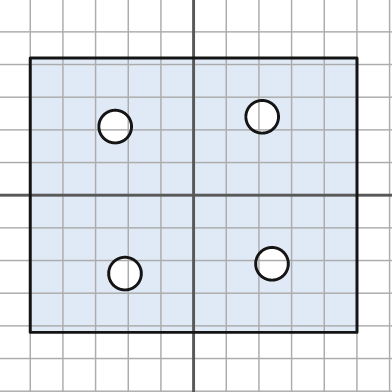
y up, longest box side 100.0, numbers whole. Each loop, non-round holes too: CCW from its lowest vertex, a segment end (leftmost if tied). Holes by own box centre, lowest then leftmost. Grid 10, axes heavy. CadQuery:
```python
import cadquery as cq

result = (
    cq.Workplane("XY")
    .moveTo(-50.0, -42.0)
    .lineTo(50.0, -42.0)
    .lineTo(50.0, 42.0)
    .lineTo(-50.0, 42.0)
    .close()
    .moveTo(-21.0, -24.0)
    .circle(5.0)
    .moveTo(24.0, -21.0)
    .circle(5.0)
    .moveTo(-24.0, 21.0)
    .circle(5.0)
    .moveTo(21.0, 24.0)
    .circle(5.0)
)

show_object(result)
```